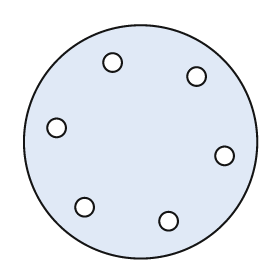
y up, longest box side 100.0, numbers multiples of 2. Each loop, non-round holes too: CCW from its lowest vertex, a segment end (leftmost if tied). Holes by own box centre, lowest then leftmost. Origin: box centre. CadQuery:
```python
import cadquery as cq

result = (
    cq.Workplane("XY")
    .moveTo(0.0, 0.0)
    .circle(50.0)
    .moveTo(12.0, -34.0)
    .circle(4.0)
    .moveTo(-24.0, -28.0)
    .circle(4.0)
    .moveTo(36.0, -6.0)
    .circle(4.0)
    .moveTo(-36.0, 6.0)
    .circle(4.0)
    .moveTo(24.0, 28.0)
    .circle(4.0)
    .moveTo(-12.0, 34.0)
    .circle(4.0)
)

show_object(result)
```